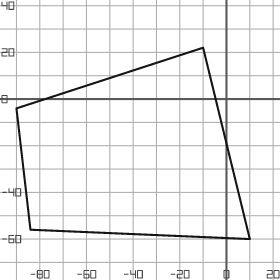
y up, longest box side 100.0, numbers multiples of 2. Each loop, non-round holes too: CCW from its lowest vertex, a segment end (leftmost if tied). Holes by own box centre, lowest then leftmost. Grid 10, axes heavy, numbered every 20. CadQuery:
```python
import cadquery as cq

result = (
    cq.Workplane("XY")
    .moveTo(10.0, -60.0)
    .lineTo(-10.0, 22.0)
    .lineTo(-90.0, -4.0)
    .lineTo(-84.0, -56.0)
    .close()
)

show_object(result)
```